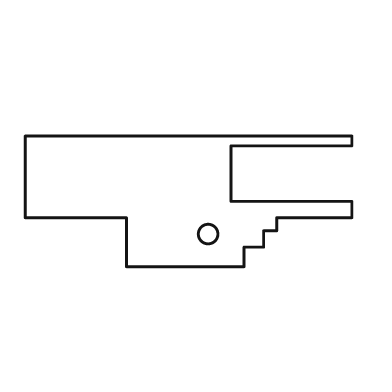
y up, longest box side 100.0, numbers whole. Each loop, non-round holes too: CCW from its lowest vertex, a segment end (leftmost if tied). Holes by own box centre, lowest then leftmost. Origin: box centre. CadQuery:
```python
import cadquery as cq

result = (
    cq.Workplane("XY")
    .moveTo(-19.0, -20.0)
    .lineTo(17.0, -20.0)
    .lineTo(17.0, -14.0)
    .lineTo(23.0, -14.0)
    .lineTo(23.0, -9.0)
    .lineTo(27.0, -9.0)
    .lineTo(27.0, -5.0)
    .lineTo(50.0, -5.0)
    .lineTo(50.0, 0.0)
    .lineTo(13.0, 0.0)
    .lineTo(13.0, 17.0)
    .lineTo(50.0, 17.0)
    .lineTo(50.0, 20.0)
    .lineTo(-50.0, 20.0)
    .lineTo(-50.0, -5.0)
    .lineTo(-19.0, -5.0)
    .close()
    .moveTo(6.0, -10.0)
    .circle(3.0)
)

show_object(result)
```